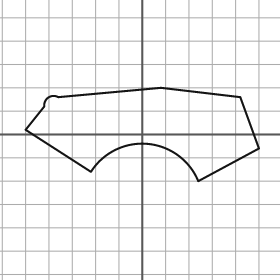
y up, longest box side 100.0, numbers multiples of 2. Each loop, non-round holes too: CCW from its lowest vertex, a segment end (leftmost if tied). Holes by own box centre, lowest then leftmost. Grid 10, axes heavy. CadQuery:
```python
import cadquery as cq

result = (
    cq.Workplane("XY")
    .moveTo(24.0, -20.0)
    .lineTo(50.0, -6.0)
    .lineTo(42.0, 16.0)
    .lineTo(8.0, 20.0)
    .lineTo(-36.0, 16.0)
    .threePointArc((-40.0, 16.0), (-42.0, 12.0))
    .lineTo(-50.0, 2.0)
    .lineTo(-22.0, -16.0)
    .threePointArc((2.0, -4.0), (24.0, -20.0))
    .close()
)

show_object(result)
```